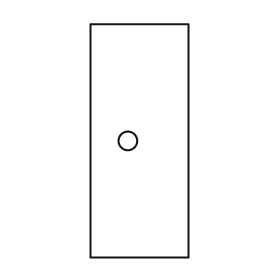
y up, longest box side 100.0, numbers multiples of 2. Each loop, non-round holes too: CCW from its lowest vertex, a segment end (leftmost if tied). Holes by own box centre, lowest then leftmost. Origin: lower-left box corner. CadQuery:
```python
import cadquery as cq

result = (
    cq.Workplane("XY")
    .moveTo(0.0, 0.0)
    .lineTo(42.0, 0.0)
    .lineTo(42.0, 100.0)
    .lineTo(0.0, 100.0)
    .close()
    .moveTo(16.0, 50.0)
    .circle(4.0)
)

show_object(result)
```